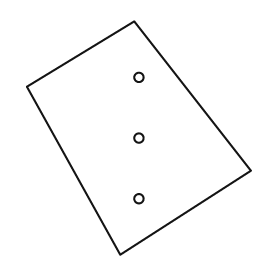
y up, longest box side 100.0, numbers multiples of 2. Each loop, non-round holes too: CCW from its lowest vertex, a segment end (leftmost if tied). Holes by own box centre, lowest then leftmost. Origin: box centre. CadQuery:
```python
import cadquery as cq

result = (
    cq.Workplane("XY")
    .moveTo(-8.0, -50.0)
    .lineTo(48.0, -14.0)
    .lineTo(-2.0, 50.0)
    .lineTo(-48.0, 22.0)
    .close()
    .moveTo(0.0, -26.0)
    .circle(2.0)
    .moveTo(0.0, 0.0)
    .circle(2.0)
    .moveTo(0.0, 26.0)
    .circle(2.0)
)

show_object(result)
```